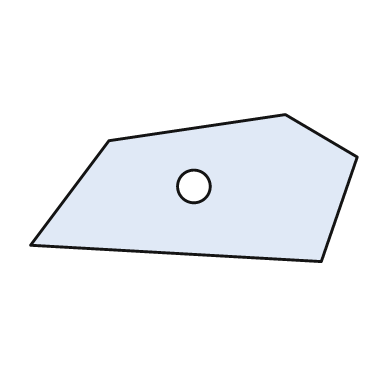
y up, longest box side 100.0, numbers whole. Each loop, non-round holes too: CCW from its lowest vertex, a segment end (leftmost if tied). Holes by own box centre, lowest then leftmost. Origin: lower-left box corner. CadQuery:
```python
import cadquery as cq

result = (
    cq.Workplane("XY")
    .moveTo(89.0, 0.0)
    .lineTo(100.0, 32.0)
    .lineTo(78.0, 45.0)
    .lineTo(24.0, 37.0)
    .lineTo(0.0, 5.0)
    .close()
    .moveTo(50.0, 23.0)
    .circle(5.0)
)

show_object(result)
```